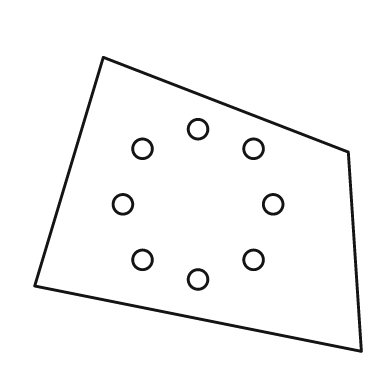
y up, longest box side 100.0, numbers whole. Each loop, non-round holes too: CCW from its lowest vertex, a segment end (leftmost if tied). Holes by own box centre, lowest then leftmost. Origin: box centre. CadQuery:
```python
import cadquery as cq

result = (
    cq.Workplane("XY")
    .moveTo(50.0, -45.0)
    .lineTo(46.0, 16.0)
    .lineTo(-29.0, 45.0)
    .lineTo(-50.0, -25.0)
    .close()
    .moveTo(0.0, -23.0)
    .circle(3.0)
    .moveTo(-17.0, -17.0)
    .circle(3.0)
    .moveTo(17.0, -17.0)
    .circle(3.0)
    .moveTo(-23.0, 0.0)
    .circle(3.0)
    .moveTo(23.0, 0.0)
    .circle(3.0)
    .moveTo(-17.0, 17.0)
    .circle(3.0)
    .moveTo(17.0, 17.0)
    .circle(3.0)
    .moveTo(0.0, 23.0)
    .circle(3.0)
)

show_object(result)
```